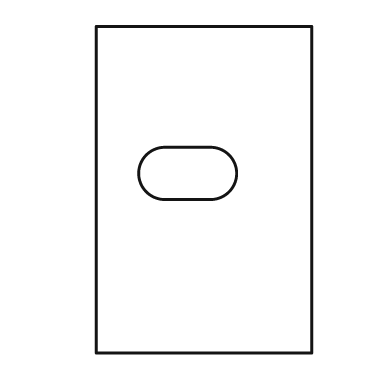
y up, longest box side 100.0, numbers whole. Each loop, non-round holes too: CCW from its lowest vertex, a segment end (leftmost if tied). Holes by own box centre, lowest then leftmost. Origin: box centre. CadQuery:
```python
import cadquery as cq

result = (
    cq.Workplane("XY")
    .moveTo(-33.0, -50.0)
    .lineTo(33.0, -50.0)
    .lineTo(33.0, 50.0)
    .lineTo(-33.0, 50.0)
    .close()
    .moveTo(-12.0, -3.0)
    .lineTo(2.0, -3.0)
    .threePointArc((10.0, 5.0), (2.0, 13.0))
    .lineTo(-12.0, 13.0)
    .threePointArc((-20.0, 5.0), (-12.0, -3.0))
    .close()
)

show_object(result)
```